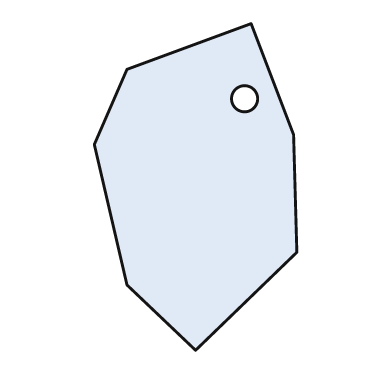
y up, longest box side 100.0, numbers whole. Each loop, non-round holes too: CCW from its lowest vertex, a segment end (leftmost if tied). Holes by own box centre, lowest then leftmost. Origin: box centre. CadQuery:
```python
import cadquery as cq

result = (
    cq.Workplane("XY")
    .moveTo(0.0, -50.0)
    .lineTo(31.0, -20.0)
    .lineTo(30.0, 16.0)
    .lineTo(17.0, 50.0)
    .lineTo(-21.0, 36.0)
    .lineTo(-31.0, 13.0)
    .lineTo(-21.0, -30.0)
    .close()
    .moveTo(15.0, 27.0)
    .circle(4.0)
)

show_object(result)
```